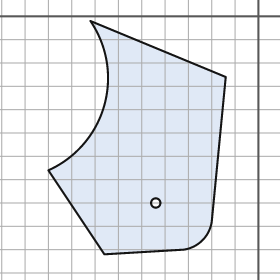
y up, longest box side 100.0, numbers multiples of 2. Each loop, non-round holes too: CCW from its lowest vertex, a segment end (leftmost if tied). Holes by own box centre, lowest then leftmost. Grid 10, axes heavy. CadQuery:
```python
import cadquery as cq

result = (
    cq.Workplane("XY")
    .moveTo(-66.0, -102.0)
    .lineTo(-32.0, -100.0)
    .threePointArc((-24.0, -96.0), (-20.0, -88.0))
    .lineTo(-14.0, -26.0)
    .lineTo(-72.0, -2.0)
    .threePointArc((-66.0, -38.0), (-90.0, -66.0))
    .close()
    .moveTo(-44.0, -80.0)
    .circle(2.0)
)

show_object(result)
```